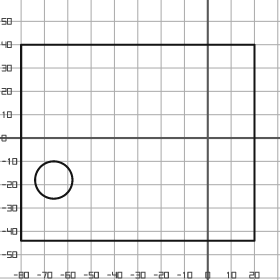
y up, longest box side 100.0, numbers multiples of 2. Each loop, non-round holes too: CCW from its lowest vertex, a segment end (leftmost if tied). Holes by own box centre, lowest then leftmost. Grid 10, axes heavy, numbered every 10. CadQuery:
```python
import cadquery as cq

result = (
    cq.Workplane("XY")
    .moveTo(-80.0, -44.0)
    .lineTo(20.0, -44.0)
    .lineTo(20.0, 40.0)
    .lineTo(-80.0, 40.0)
    .close()
    .moveTo(-66.0, -18.0)
    .circle(8.0)
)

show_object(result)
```